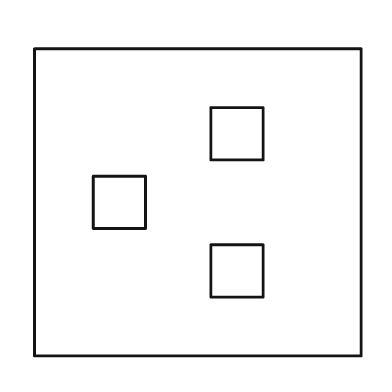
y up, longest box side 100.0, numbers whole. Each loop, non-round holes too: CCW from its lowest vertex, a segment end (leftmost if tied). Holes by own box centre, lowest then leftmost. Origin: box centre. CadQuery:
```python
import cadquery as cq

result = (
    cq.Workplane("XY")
    .moveTo(-50.0, -47.0)
    .lineTo(50.0, -47.0)
    .lineTo(50.0, 47.0)
    .lineTo(-50.0, 47.0)
    .close()
    .moveTo(4.0, -29.0)
    .lineTo(20.0, -29.0)
    .lineTo(20.0, -13.0)
    .lineTo(4.0, -13.0)
    .close()
    .moveTo(-32.0, -8.0)
    .lineTo(-16.0, -8.0)
    .lineTo(-16.0, 8.0)
    .lineTo(-32.0, 8.0)
    .close()
    .moveTo(4.0, 13.0)
    .lineTo(20.0, 13.0)
    .lineTo(20.0, 29.0)
    .lineTo(4.0, 29.0)
    .close()
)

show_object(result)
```